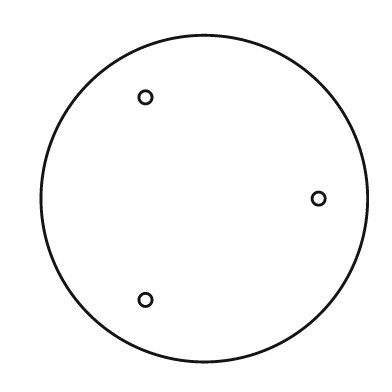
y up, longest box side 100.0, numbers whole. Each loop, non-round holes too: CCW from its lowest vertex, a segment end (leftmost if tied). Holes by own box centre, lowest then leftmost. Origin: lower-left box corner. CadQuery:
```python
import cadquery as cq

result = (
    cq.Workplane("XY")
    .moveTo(50.0, 50.0)
    .circle(50.0)
    .moveTo(32.0, 19.0)
    .circle(2.0)
    .moveTo(85.0, 50.0)
    .circle(2.0)
    .moveTo(32.0, 81.0)
    .circle(2.0)
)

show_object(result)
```